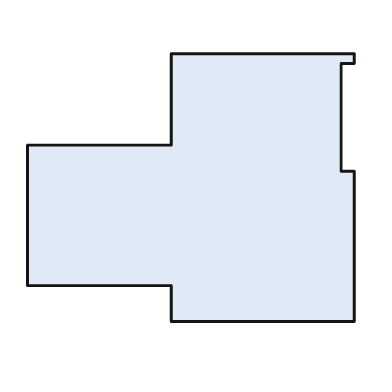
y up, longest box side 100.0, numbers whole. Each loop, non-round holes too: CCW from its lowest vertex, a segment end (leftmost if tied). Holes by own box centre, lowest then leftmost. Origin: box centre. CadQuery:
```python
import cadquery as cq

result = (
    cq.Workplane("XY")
    .moveTo(-6.0, -41.0)
    .lineTo(50.0, -41.0)
    .lineTo(50.0, 5.0)
    .lineTo(46.0, 5.0)
    .lineTo(46.0, 38.0)
    .lineTo(50.0, 38.0)
    .lineTo(50.0, 41.0)
    .lineTo(-6.0, 41.0)
    .lineTo(-6.0, 13.0)
    .lineTo(-50.0, 13.0)
    .lineTo(-50.0, -30.0)
    .lineTo(-6.0, -30.0)
    .close()
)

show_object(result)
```